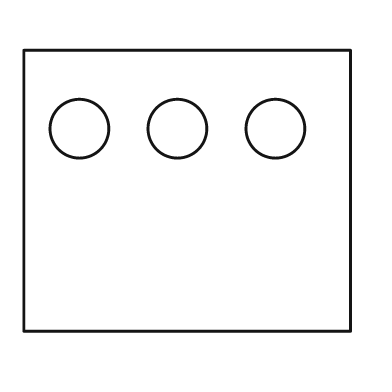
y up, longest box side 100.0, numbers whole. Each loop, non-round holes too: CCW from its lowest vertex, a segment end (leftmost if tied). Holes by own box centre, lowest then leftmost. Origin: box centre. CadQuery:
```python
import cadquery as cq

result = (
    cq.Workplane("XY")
    .moveTo(-50.0, -43.0)
    .lineTo(50.0, -43.0)
    .lineTo(50.0, 43.0)
    .lineTo(-50.0, 43.0)
    .close()
    .moveTo(-33.0, 19.0)
    .circle(9.0)
    .moveTo(-3.0, 19.0)
    .circle(9.0)
    .moveTo(27.0, 19.0)
    .circle(9.0)
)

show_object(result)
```